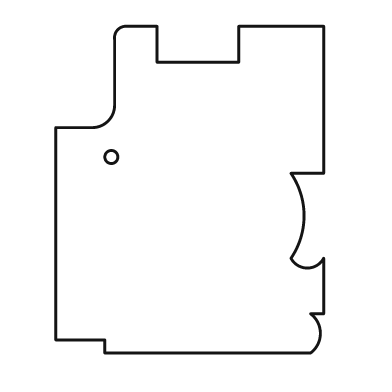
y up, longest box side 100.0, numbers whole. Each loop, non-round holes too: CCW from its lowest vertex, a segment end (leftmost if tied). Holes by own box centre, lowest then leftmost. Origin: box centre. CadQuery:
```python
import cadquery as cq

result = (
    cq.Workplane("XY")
    .moveTo(-26.0, -50.0)
    .lineTo(37.0, -50.0)
    .threePointArc((40.0, -44.0), (37.0, -38.0))
    .lineTo(41.0, -38.0)
    .lineTo(41.0, -21.0)
    .threePointArc((36.0, -24.0), (31.0, -21.0))
    .threePointArc((35.0, -8.0), (31.0, 5.0))
    .lineTo(41.0, 5.0)
    .lineTo(41.0, 50.0)
    .lineTo(15.0, 50.0)
    .lineTo(15.0, 39.0)
    .lineTo(-10.0, 39.0)
    .lineTo(-10.0, 50.0)
    .lineTo(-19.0, 50.0)
    .threePointArc((-22.0, 49.0), (-23.0, 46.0))
    .lineTo(-23.0, 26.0)
    .threePointArc((-25.0, 21.0), (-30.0, 19.0))
    .lineTo(-41.0, 19.0)
    .lineTo(-41.0, -46.0)
    .lineTo(-26.0, -46.0)
    .close()
    .moveTo(-24.0, 10.0)
    .circle(2.0)
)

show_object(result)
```